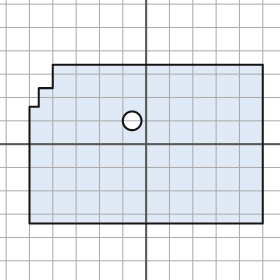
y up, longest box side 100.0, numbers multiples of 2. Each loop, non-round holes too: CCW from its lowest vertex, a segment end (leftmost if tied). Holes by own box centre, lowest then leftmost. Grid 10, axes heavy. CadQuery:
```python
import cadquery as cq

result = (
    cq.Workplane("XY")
    .moveTo(-50.0, -34.0)
    .lineTo(50.0, -34.0)
    .lineTo(50.0, 34.0)
    .lineTo(-40.0, 34.0)
    .lineTo(-40.0, 24.0)
    .lineTo(-46.0, 24.0)
    .lineTo(-46.0, 16.0)
    .lineTo(-50.0, 16.0)
    .close()
    .moveTo(-6.0, 10.0)
    .circle(4.0)
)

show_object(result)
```